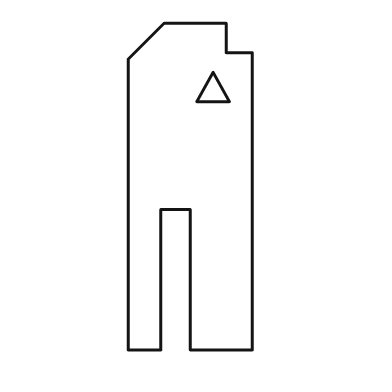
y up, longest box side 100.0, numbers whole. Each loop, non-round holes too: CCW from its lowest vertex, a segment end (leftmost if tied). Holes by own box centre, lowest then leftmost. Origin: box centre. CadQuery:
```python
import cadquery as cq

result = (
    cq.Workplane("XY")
    .moveTo(-19.0, -50.0)
    .lineTo(-9.0, -50.0)
    .lineTo(-9.0, -7.0)
    .lineTo(0.0, -7.0)
    .lineTo(0.0, -50.0)
    .lineTo(19.0, -50.0)
    .lineTo(19.0, 41.0)
    .lineTo(11.0, 41.0)
    .lineTo(11.0, 50.0)
    .lineTo(-8.0, 50.0)
    .lineTo(-19.0, 39.0)
    .close()
    .moveTo(2.0, 26.0)
    .lineTo(12.0, 26.0)
    .lineTo(7.0, 35.0)
    .close()
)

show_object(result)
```